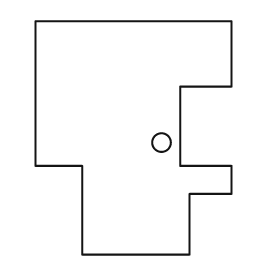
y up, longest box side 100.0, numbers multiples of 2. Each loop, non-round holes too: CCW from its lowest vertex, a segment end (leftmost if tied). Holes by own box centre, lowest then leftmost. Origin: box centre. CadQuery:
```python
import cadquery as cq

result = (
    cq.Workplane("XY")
    .moveTo(-22.0, -50.0)
    .lineTo(24.0, -50.0)
    .lineTo(24.0, -24.0)
    .lineTo(42.0, -24.0)
    .lineTo(42.0, -12.0)
    .lineTo(20.0, -12.0)
    .lineTo(20.0, 22.0)
    .lineTo(42.0, 22.0)
    .lineTo(42.0, 50.0)
    .lineTo(-42.0, 50.0)
    .lineTo(-42.0, -12.0)
    .lineTo(-22.0, -12.0)
    .close()
    .moveTo(12.0, -2.0)
    .circle(4.0)
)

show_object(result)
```